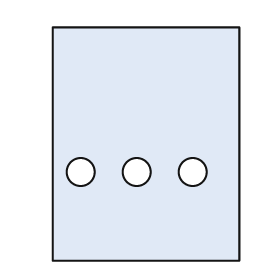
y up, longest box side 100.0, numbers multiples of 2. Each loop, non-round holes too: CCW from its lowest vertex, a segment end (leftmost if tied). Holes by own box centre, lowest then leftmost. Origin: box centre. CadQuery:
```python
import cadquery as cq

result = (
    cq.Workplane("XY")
    .moveTo(-40.0, -50.0)
    .lineTo(40.0, -50.0)
    .lineTo(40.0, 50.0)
    .lineTo(-40.0, 50.0)
    .close()
    .moveTo(-28.0, -12.0)
    .circle(6.0)
    .moveTo(-4.0, -12.0)
    .circle(6.0)
    .moveTo(20.0, -12.0)
    .circle(6.0)
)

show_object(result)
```